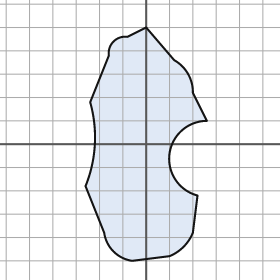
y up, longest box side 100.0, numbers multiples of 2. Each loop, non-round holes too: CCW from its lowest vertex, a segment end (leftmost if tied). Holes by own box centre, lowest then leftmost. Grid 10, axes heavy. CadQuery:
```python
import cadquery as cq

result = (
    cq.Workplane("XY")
    .moveTo(-6.0, -50.0)
    .lineTo(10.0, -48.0)
    .threePointArc((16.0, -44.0), (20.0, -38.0))
    .lineTo(22.0, -22.0)
    .threePointArc((10.0, -4.0), (26.0, 10.0))
    .lineTo(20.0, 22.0)
    .threePointArc((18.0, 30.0), (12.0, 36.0))
    .lineTo(0.0, 50.0)
    .lineTo(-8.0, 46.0)
    .threePointArc((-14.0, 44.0), (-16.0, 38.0))
    .lineTo(-24.0, 18.0)
    .threePointArc((-22.0, 0.0), (-26.0, -18.0))
    .lineTo(-18.0, -38.0)
    .threePointArc((-14.0, -46.0), (-6.0, -50.0))
    .close()
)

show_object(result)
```